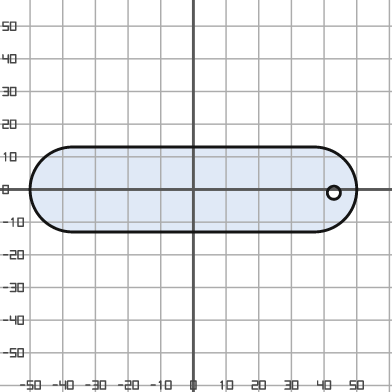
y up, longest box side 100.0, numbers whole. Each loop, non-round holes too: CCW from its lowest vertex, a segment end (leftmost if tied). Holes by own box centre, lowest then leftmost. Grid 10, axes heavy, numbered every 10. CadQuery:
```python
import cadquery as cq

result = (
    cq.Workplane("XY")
    .moveTo(-37.0, -13.0)
    .lineTo(37.0, -13.0)
    .threePointArc((50.0, 0.0), (37.0, 13.0))
    .lineTo(-37.0, 13.0)
    .threePointArc((-50.0, 0.0), (-37.0, -13.0))
    .close()
    .moveTo(43.0, -1.0)
    .circle(2.0)
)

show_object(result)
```